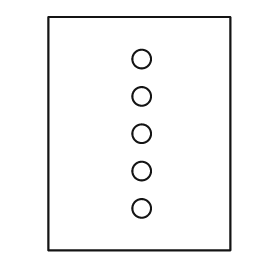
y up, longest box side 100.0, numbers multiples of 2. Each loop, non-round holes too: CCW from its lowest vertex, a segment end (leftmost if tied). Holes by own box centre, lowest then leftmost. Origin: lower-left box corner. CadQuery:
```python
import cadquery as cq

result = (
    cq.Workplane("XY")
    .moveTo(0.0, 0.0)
    .lineTo(78.0, 0.0)
    .lineTo(78.0, 100.0)
    .lineTo(0.0, 100.0)
    .close()
    .moveTo(40.0, 18.0)
    .circle(4.0)
    .moveTo(40.0, 34.0)
    .circle(4.0)
    .moveTo(40.0, 50.0)
    .circle(4.0)
    .moveTo(40.0, 66.0)
    .circle(4.0)
    .moveTo(40.0, 82.0)
    .circle(4.0)
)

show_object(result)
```